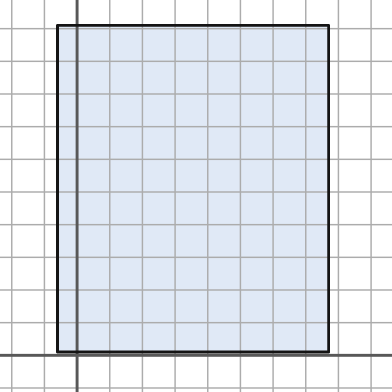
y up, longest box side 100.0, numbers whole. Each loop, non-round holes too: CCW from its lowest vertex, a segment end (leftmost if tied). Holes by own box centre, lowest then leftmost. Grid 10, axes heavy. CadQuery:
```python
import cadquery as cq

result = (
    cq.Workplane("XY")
    .moveTo(-6.0, 1.0)
    .lineTo(77.0, 1.0)
    .lineTo(77.0, 101.0)
    .lineTo(-6.0, 101.0)
    .close()
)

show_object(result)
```